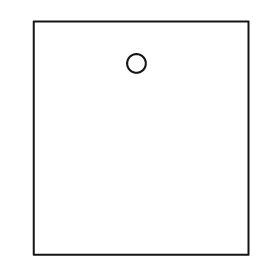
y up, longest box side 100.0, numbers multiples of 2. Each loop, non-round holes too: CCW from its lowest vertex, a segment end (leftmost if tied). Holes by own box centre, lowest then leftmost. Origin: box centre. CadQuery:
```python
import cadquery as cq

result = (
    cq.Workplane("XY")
    .moveTo(-46.0, -50.0)
    .lineTo(46.0, -50.0)
    .lineTo(46.0, 50.0)
    .lineTo(-46.0, 50.0)
    .close()
    .moveTo(-2.0, 32.0)
    .circle(4.0)
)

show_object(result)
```